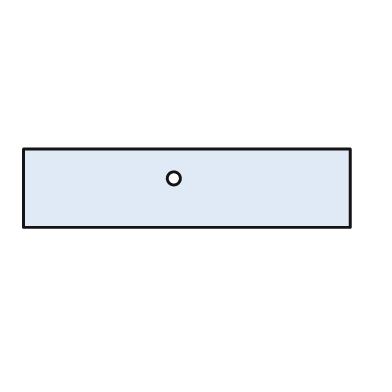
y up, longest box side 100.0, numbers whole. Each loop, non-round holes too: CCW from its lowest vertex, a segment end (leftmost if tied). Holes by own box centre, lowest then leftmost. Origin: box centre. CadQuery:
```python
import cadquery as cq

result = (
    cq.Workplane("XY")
    .moveTo(-50.0, -12.0)
    .lineTo(50.0, -12.0)
    .lineTo(50.0, 12.0)
    .lineTo(-50.0, 12.0)
    .close()
    .moveTo(-4.0, 3.0)
    .circle(2.0)
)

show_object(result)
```